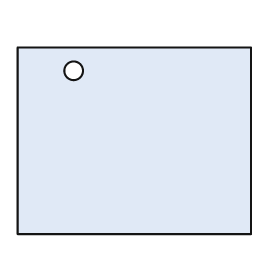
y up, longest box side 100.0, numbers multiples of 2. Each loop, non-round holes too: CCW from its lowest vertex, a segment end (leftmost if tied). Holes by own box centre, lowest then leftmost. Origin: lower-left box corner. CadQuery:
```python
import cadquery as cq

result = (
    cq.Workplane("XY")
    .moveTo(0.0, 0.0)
    .lineTo(100.0, 0.0)
    .lineTo(100.0, 80.0)
    .lineTo(0.0, 80.0)
    .close()
    .moveTo(24.0, 70.0)
    .circle(4.0)
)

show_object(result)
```